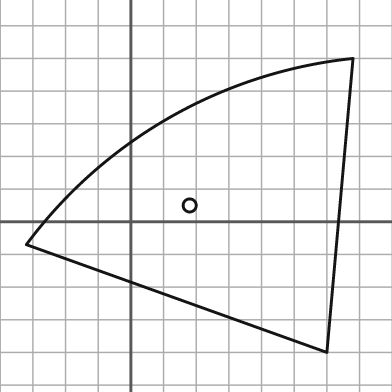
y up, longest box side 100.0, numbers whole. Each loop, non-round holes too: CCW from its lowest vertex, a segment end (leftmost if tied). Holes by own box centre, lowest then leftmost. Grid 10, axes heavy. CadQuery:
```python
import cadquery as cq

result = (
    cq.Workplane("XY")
    .moveTo(60.0, -40.0)
    .lineTo(68.0, 50.0)
    .threePointArc((12.0, 32.0), (-32.0, -7.0))
    .close()
    .moveTo(18.0, 5.0)
    .circle(2.0)
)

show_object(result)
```